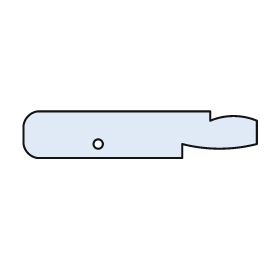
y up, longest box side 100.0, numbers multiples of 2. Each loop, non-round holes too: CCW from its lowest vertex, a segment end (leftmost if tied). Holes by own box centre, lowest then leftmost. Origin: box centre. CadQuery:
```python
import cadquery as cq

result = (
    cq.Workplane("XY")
    .moveTo(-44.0, -10.0)
    .lineTo(18.0, -10.0)
    .lineTo(18.0, -4.0)
    .threePointArc((34.0, -6.0), (50.0, -4.0))
    .lineTo(50.0, 6.0)
    .threePointArc((40.0, 8.0), (30.0, 6.0))
    .lineTo(30.0, 10.0)
    .lineTo(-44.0, 10.0)
    .threePointArc((-48.0, 8.0), (-50.0, 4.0))
    .lineTo(-50.0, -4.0)
    .threePointArc((-48.0, -8.0), (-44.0, -10.0))
    .close()
    .moveTo(-18.0, -4.0)
    .circle(2.0)
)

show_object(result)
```